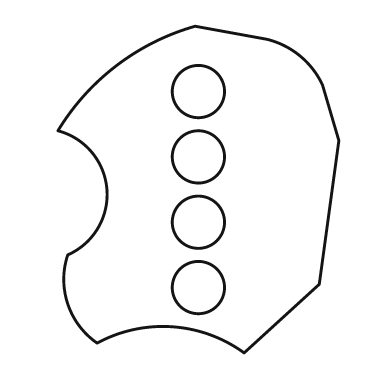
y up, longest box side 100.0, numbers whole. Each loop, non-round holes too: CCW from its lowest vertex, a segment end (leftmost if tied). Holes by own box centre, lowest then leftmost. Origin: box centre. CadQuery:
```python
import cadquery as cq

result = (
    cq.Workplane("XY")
    .moveTo(14.0, -50.0)
    .lineTo(37.0, -29.0)
    .lineTo(43.0, 15.0)
    .lineTo(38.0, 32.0)
    .threePointArc((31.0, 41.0), (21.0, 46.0))
    .lineTo(-1.0, 50.0)
    .threePointArc((-25.0, 38.0), (-43.0, 18.0))
    .threePointArc((-28.0, 0.0), (-40.0, -20.0))
    .threePointArc((-40.0, -35.0), (-31.0, -47.0))
    .threePointArc((-8.0, -42.0), (14.0, -50.0))
    .close()
    .moveTo(0.0, -30.0)
    .circle(8.0)
    .moveTo(0.0, -10.0)
    .circle(8.0)
    .moveTo(0.0, 10.0)
    .circle(8.0)
    .moveTo(0.0, 30.0)
    .circle(8.0)
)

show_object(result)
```